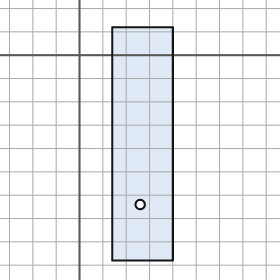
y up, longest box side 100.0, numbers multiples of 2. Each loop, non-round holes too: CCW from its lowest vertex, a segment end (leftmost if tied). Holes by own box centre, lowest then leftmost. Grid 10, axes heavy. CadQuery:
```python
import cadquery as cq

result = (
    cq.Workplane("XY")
    .moveTo(14.0, -88.0)
    .lineTo(40.0, -88.0)
    .lineTo(40.0, 12.0)
    .lineTo(14.0, 12.0)
    .close()
    .moveTo(26.0, -64.0)
    .circle(2.0)
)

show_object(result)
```